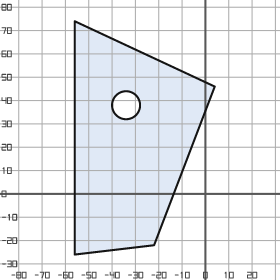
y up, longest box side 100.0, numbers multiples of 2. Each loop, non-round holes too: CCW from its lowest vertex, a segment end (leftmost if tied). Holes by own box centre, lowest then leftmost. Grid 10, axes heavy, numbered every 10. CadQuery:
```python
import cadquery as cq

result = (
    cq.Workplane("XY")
    .moveTo(-56.0, -26.0)
    .lineTo(-22.0, -22.0)
    .lineTo(4.0, 46.0)
    .lineTo(-56.0, 74.0)
    .close()
    .moveTo(-34.0, 38.0)
    .circle(6.0)
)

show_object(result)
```